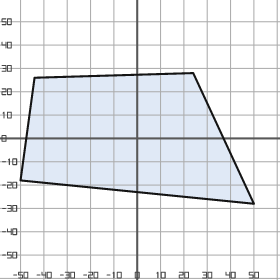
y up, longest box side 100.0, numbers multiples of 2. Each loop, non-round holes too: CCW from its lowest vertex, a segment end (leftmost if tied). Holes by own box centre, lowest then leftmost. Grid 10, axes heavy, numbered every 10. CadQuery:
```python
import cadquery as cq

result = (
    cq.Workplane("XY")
    .moveTo(50.0, -28.0)
    .lineTo(24.0, 28.0)
    .lineTo(-44.0, 26.0)
    .lineTo(-50.0, -18.0)
    .close()
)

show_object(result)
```